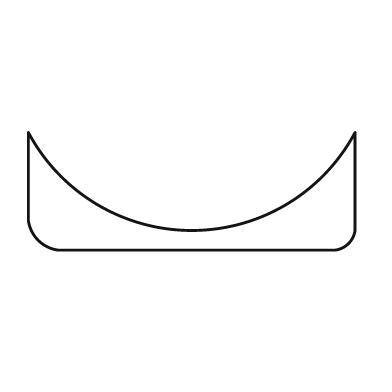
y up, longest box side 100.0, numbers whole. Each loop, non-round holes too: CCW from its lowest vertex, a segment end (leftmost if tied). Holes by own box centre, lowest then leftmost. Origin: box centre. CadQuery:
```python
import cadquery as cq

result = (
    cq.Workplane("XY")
    .moveTo(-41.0, -18.0)
    .lineTo(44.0, -18.0)
    .threePointArc((48.0, -16.0), (50.0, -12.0))
    .lineTo(50.0, 18.0)
    .threePointArc((0.0, -12.0), (-50.0, 18.0))
    .lineTo(-50.0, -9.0)
    .threePointArc((-47.0, -15.0), (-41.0, -18.0))
    .close()
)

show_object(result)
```